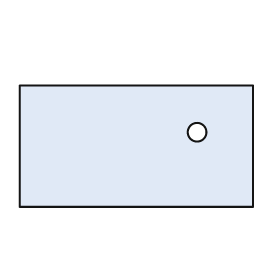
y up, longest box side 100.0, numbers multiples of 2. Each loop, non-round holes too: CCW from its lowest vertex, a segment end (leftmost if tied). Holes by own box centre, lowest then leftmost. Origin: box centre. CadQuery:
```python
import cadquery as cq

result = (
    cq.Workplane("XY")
    .moveTo(-50.0, -26.0)
    .lineTo(50.0, -26.0)
    .lineTo(50.0, 26.0)
    .lineTo(-50.0, 26.0)
    .close()
    .moveTo(26.0, 6.0)
    .circle(4.0)
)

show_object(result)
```